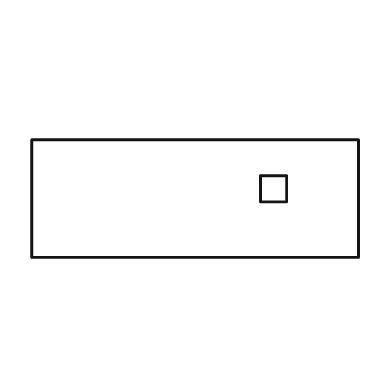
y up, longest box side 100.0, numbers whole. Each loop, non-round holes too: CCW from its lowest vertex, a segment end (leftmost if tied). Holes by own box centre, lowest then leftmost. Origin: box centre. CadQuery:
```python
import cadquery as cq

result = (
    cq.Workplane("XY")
    .moveTo(-50.0, -18.0)
    .lineTo(50.0, -18.0)
    .lineTo(50.0, 18.0)
    .lineTo(-50.0, 18.0)
    .close()
    .moveTo(20.0, -1.0)
    .lineTo(28.0, -1.0)
    .lineTo(28.0, 7.0)
    .lineTo(20.0, 7.0)
    .close()
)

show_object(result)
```